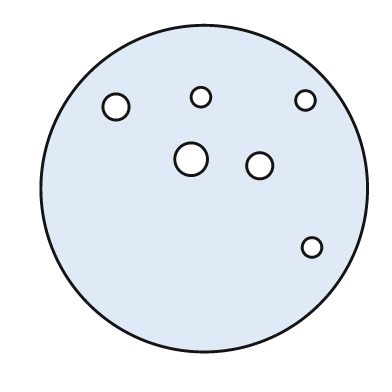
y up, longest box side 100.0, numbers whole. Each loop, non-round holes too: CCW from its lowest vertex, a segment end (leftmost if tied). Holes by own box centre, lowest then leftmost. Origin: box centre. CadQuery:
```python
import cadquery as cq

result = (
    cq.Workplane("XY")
    .moveTo(0.0, 0.0)
    .circle(50.0)
    .moveTo(33.0, -18.0)
    .circle(3.0)
    .moveTo(17.0, 7.0)
    .circle(4.0)
    .moveTo(-4.0, 9.0)
    .circle(5.0)
    .moveTo(-27.0, 25.0)
    .circle(4.0)
    .moveTo(31.0, 27.0)
    .circle(3.0)
    .moveTo(-1.0, 28.0)
    .circle(3.0)
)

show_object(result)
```